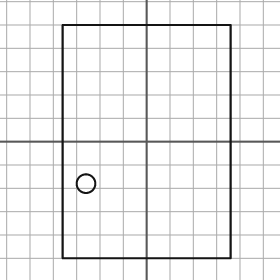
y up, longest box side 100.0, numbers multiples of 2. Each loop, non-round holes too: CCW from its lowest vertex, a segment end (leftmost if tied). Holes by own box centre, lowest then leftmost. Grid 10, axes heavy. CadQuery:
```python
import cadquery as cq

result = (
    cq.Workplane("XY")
    .moveTo(-36.0, -50.0)
    .lineTo(36.0, -50.0)
    .lineTo(36.0, 50.0)
    .lineTo(-36.0, 50.0)
    .close()
    .moveTo(-26.0, -18.0)
    .circle(4.0)
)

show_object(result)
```